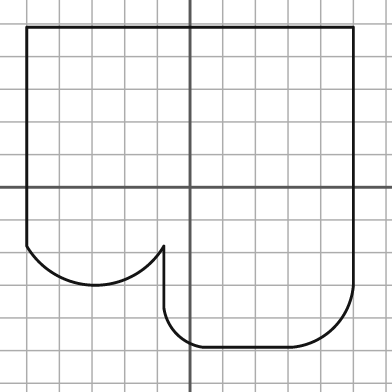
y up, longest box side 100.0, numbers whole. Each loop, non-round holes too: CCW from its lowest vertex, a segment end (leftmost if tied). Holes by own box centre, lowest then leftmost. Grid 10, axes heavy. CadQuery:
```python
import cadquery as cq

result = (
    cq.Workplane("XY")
    .moveTo(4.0, -49.0)
    .lineTo(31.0, -49.0)
    .threePointArc((44.0, -43.0), (50.0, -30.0))
    .lineTo(50.0, 49.0)
    .lineTo(-50.0, 49.0)
    .lineTo(-50.0, -18.0)
    .threePointArc((-29.0, -30.0), (-8.0, -18.0))
    .lineTo(-8.0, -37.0)
    .threePointArc((-4.0, -45.0), (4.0, -49.0))
    .close()
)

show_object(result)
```